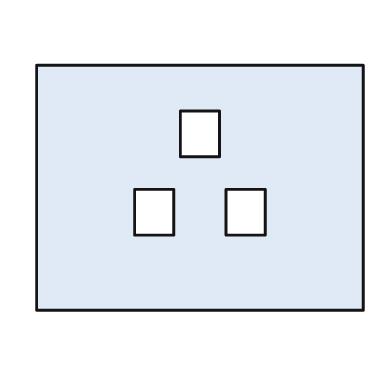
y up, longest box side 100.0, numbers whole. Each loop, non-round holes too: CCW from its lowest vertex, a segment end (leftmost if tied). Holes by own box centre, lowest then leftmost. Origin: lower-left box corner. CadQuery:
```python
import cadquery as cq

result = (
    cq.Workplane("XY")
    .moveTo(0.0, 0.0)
    .lineTo(100.0, 0.0)
    .lineTo(100.0, 75.0)
    .lineTo(0.0, 75.0)
    .close()
    .moveTo(30.0, 23.0)
    .lineTo(42.0, 23.0)
    .lineTo(42.0, 37.0)
    .lineTo(30.0, 37.0)
    .close()
    .moveTo(58.0, 23.0)
    .lineTo(70.0, 23.0)
    .lineTo(70.0, 37.0)
    .lineTo(58.0, 37.0)
    .close()
    .moveTo(44.0, 47.0)
    .lineTo(56.0, 47.0)
    .lineTo(56.0, 61.0)
    .lineTo(44.0, 61.0)
    .close()
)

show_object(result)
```